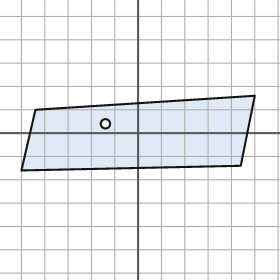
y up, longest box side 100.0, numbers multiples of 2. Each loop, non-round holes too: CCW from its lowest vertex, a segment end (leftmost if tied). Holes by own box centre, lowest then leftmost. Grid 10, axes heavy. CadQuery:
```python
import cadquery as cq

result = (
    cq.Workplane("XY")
    .moveTo(-50.0, -16.0)
    .lineTo(44.0, -14.0)
    .lineTo(50.0, 16.0)
    .lineTo(-44.0, 10.0)
    .close()
    .moveTo(-14.0, 4.0)
    .circle(2.0)
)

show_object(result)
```